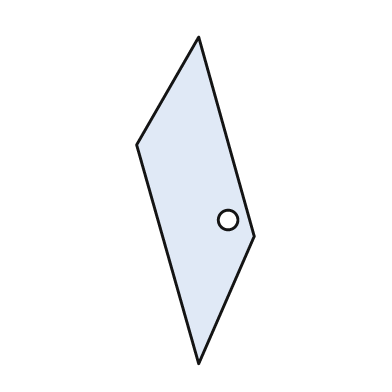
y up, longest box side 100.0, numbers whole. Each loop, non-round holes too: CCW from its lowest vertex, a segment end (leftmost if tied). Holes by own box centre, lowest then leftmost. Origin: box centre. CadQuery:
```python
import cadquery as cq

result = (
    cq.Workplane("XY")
    .moveTo(1.0, -50.0)
    .lineTo(18.0, -11.0)
    .lineTo(1.0, 50.0)
    .lineTo(-18.0, 17.0)
    .close()
    .moveTo(10.0, -6.0)
    .circle(3.0)
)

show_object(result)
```